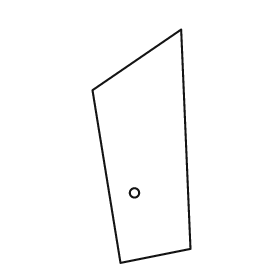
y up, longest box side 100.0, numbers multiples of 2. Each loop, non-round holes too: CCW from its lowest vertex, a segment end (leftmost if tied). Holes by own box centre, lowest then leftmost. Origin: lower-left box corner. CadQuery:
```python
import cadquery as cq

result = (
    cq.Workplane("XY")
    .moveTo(12.0, 0.0)
    .lineTo(42.0, 6.0)
    .lineTo(38.0, 100.0)
    .lineTo(0.0, 74.0)
    .close()
    .moveTo(18.0, 30.0)
    .circle(2.0)
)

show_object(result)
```